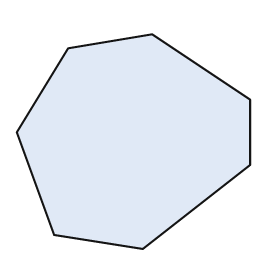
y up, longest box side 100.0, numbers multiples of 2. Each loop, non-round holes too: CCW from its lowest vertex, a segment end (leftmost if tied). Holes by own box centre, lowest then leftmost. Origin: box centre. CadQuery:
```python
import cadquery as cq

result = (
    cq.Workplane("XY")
    .moveTo(4.0, -46.0)
    .lineTo(50.0, -10.0)
    .lineTo(50.0, 18.0)
    .lineTo(8.0, 46.0)
    .lineTo(-28.0, 40.0)
    .lineTo(-50.0, 4.0)
    .lineTo(-34.0, -40.0)
    .close()
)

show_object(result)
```